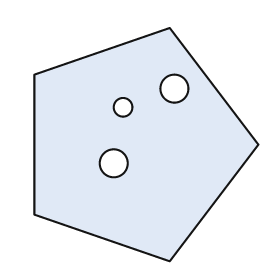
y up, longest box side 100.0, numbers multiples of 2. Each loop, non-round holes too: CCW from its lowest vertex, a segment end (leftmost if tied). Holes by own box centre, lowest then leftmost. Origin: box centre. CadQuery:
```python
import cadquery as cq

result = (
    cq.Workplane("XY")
    .moveTo(10.0, -50.0)
    .lineTo(48.0, 0.0)
    .lineTo(10.0, 50.0)
    .lineTo(-48.0, 30.0)
    .lineTo(-48.0, -30.0)
    .close()
    .moveTo(-14.0, -8.0)
    .circle(6.0)
    .moveTo(-10.0, 16.0)
    .circle(4.0)
    .moveTo(12.0, 24.0)
    .circle(6.0)
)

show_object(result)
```